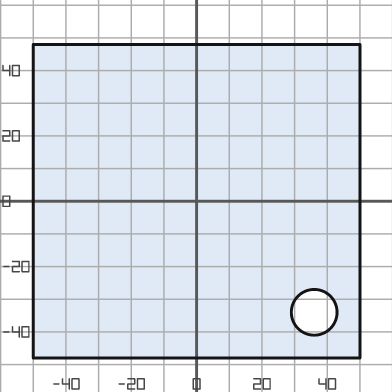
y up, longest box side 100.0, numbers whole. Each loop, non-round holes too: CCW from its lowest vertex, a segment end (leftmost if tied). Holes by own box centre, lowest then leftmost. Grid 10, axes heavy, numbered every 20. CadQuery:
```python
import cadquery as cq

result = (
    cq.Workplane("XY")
    .moveTo(-50.0, -48.0)
    .lineTo(50.0, -48.0)
    .lineTo(50.0, 48.0)
    .lineTo(-50.0, 48.0)
    .close()
    .moveTo(36.0, -34.0)
    .circle(7.0)
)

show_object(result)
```